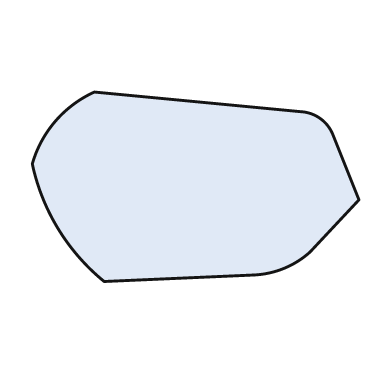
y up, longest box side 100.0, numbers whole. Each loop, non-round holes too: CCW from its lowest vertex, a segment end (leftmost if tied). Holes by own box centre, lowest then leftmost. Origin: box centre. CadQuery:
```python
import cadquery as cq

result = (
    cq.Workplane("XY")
    .moveTo(-28.0, -29.0)
    .lineTo(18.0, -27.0)
    .threePointArc((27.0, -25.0), (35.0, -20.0))
    .lineTo(50.0, -4.0)
    .lineTo(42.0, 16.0)
    .threePointArc((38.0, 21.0), (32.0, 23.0))
    .lineTo(-31.0, 29.0)
    .threePointArc((-43.0, 20.0), (-50.0, 7.0))
    .threePointArc((-42.0, -13.0), (-28.0, -29.0))
    .close()
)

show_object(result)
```